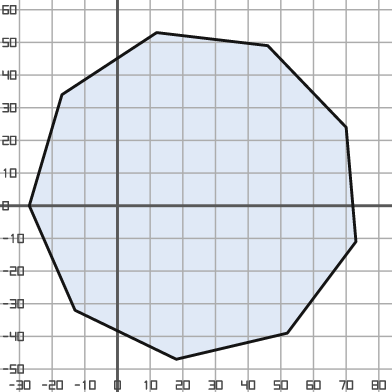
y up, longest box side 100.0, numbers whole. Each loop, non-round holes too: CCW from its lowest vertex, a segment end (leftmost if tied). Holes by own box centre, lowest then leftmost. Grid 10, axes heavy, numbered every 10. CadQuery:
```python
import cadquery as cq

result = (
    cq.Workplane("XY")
    .moveTo(18.0, -47.0)
    .lineTo(52.0, -39.0)
    .lineTo(73.0, -11.0)
    .lineTo(70.0, 24.0)
    .lineTo(46.0, 49.0)
    .lineTo(12.0, 53.0)
    .lineTo(-17.0, 34.0)
    .lineTo(-27.0, 0.0)
    .lineTo(-13.0, -32.0)
    .close()
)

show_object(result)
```